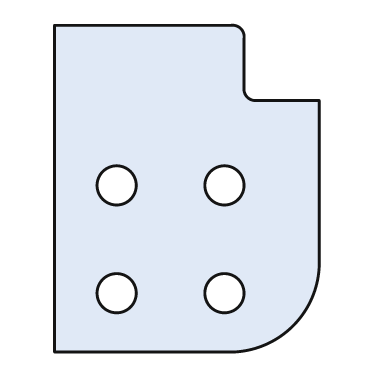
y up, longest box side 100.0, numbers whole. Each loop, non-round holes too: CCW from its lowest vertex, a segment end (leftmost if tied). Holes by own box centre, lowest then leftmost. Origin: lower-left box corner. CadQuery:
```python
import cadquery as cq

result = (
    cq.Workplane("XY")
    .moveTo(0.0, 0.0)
    .lineTo(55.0, 0.0)
    .threePointArc((73.0, 8.0), (81.0, 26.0))
    .lineTo(81.0, 77.0)
    .lineTo(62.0, 77.0)
    .threePointArc((59.0, 78.0), (58.0, 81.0))
    .lineTo(58.0, 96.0)
    .threePointArc((57.0, 99.0), (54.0, 100.0))
    .lineTo(0.0, 100.0)
    .close()
    .moveTo(19.0, 18.0)
    .circle(6.0)
    .moveTo(52.0, 18.0)
    .circle(6.0)
    .moveTo(19.0, 51.0)
    .circle(6.0)
    .moveTo(52.0, 51.0)
    .circle(6.0)
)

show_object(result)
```